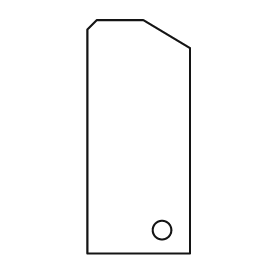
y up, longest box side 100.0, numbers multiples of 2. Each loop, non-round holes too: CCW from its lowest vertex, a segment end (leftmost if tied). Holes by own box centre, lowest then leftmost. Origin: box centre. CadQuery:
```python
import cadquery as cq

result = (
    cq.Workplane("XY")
    .moveTo(-22.0, -50.0)
    .lineTo(22.0, -50.0)
    .lineTo(22.0, 38.0)
    .lineTo(2.0, 50.0)
    .lineTo(-18.0, 50.0)
    .lineTo(-22.0, 46.0)
    .close()
    .moveTo(10.0, -40.0)
    .circle(4.0)
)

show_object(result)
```